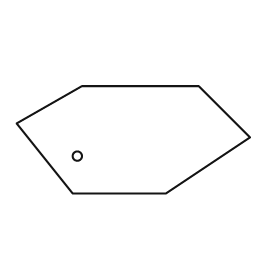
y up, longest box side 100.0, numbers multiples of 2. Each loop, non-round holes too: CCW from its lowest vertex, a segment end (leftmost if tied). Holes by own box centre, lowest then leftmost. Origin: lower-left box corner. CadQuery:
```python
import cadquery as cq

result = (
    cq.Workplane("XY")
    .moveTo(24.0, 0.0)
    .lineTo(64.0, 0.0)
    .lineTo(100.0, 24.0)
    .lineTo(78.0, 46.0)
    .lineTo(28.0, 46.0)
    .lineTo(0.0, 30.0)
    .close()
    .moveTo(26.0, 16.0)
    .circle(2.0)
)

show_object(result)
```